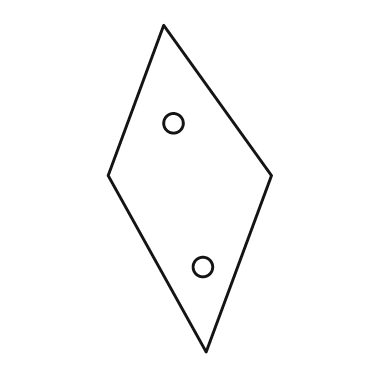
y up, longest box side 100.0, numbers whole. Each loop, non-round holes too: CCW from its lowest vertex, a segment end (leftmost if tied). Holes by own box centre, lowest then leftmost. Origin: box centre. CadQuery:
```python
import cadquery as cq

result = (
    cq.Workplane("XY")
    .moveTo(5.0, -50.0)
    .lineTo(25.0, 4.0)
    .lineTo(-8.0, 50.0)
    .lineTo(-25.0, 4.0)
    .close()
    .moveTo(4.0, -24.0)
    .circle(3.0)
    .moveTo(-5.0, 20.0)
    .circle(3.0)
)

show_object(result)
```